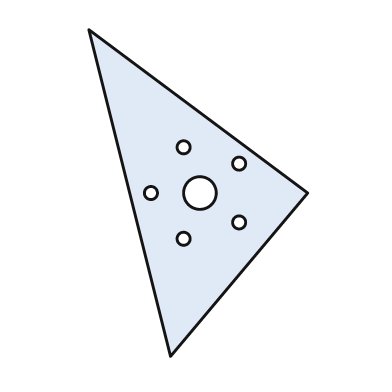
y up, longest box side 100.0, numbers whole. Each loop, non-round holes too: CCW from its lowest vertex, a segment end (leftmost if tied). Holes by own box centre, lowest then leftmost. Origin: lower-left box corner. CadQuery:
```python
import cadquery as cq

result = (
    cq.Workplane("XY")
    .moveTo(25.0, 0.0)
    .lineTo(67.0, 50.0)
    .lineTo(0.0, 100.0)
    .close()
    .moveTo(29.0, 36.0)
    .circle(2.0)
    .moveTo(46.0, 41.0)
    .circle(2.0)
    .moveTo(19.0, 50.0)
    .circle(2.0)
    .moveTo(34.0, 50.0)
    .circle(5.0)
    .moveTo(46.0, 59.0)
    .circle(2.0)
    .moveTo(29.0, 64.0)
    .circle(2.0)
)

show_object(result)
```